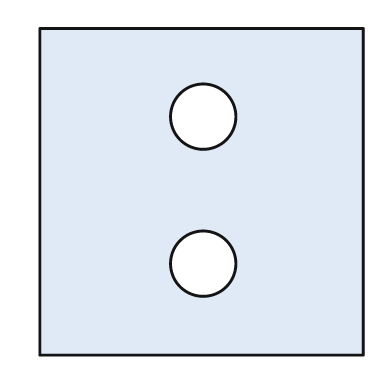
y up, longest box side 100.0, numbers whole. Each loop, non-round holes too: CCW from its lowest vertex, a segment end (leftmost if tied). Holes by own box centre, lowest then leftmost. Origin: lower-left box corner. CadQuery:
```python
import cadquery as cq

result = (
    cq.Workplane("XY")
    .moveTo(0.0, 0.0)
    .lineTo(99.0, 0.0)
    .lineTo(99.0, 100.0)
    .lineTo(0.0, 100.0)
    .close()
    .moveTo(50.0, 28.0)
    .circle(10.0)
    .moveTo(50.0, 73.0)
    .circle(10.0)
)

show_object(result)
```